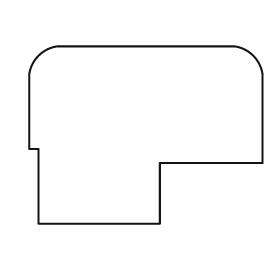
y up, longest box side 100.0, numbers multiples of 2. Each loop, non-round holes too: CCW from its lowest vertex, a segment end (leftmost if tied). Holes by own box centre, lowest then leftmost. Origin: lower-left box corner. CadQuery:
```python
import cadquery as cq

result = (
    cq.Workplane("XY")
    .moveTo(4.0, 0.0)
    .lineTo(56.0, 0.0)
    .lineTo(56.0, 26.0)
    .lineTo(100.0, 26.0)
    .lineTo(100.0, 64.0)
    .threePointArc((96.0, 72.0), (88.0, 76.0))
    .lineTo(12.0, 76.0)
    .threePointArc((4.0, 72.0), (0.0, 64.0))
    .lineTo(0.0, 32.0)
    .lineTo(4.0, 32.0)
    .close()
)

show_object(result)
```